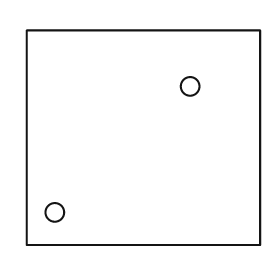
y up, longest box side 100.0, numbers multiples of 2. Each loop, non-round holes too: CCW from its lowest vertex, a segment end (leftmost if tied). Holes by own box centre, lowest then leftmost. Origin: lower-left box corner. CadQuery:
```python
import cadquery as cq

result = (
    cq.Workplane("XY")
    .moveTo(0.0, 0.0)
    .lineTo(100.0, 0.0)
    .lineTo(100.0, 92.0)
    .lineTo(0.0, 92.0)
    .close()
    .moveTo(12.0, 14.0)
    .circle(4.0)
    .moveTo(70.0, 68.0)
    .circle(4.0)
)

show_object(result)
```